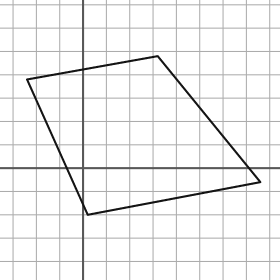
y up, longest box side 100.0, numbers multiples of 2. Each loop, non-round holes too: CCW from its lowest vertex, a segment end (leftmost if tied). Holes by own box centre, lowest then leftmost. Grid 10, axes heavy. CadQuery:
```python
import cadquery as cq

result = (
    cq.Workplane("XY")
    .moveTo(2.0, -20.0)
    .lineTo(76.0, -6.0)
    .lineTo(32.0, 48.0)
    .lineTo(-24.0, 38.0)
    .close()
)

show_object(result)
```